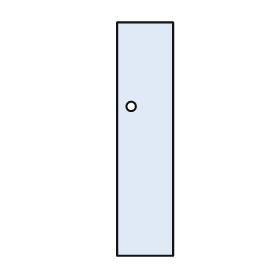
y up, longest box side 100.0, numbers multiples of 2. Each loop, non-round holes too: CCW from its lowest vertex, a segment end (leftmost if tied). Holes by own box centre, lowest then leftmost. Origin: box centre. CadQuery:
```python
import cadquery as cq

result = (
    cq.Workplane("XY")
    .moveTo(-12.0, -50.0)
    .lineTo(12.0, -50.0)
    .lineTo(12.0, 50.0)
    .lineTo(-12.0, 50.0)
    .close()
    .moveTo(-6.0, 14.0)
    .circle(2.0)
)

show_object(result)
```